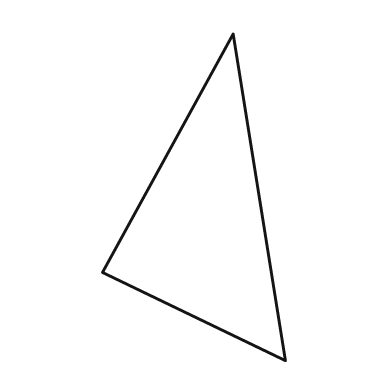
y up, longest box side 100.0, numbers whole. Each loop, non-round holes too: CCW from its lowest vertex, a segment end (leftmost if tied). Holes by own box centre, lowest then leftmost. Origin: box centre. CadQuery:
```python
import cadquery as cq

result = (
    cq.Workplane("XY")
    .moveTo(28.0, -50.0)
    .lineTo(12.0, 50.0)
    .lineTo(-28.0, -23.0)
    .close()
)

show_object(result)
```